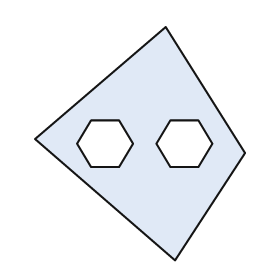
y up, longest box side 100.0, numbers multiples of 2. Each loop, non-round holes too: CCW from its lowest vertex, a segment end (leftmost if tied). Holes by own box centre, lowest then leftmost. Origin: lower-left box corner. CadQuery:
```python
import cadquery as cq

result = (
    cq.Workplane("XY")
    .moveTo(60.0, 0.0)
    .lineTo(90.0, 46.0)
    .lineTo(56.0, 100.0)
    .lineTo(0.0, 52.0)
    .close()
    .moveTo(24.0, 40.0)
    .lineTo(36.0, 40.0)
    .lineTo(42.0, 50.0)
    .lineTo(36.0, 60.0)
    .lineTo(24.0, 60.0)
    .lineTo(18.0, 50.0)
    .close()
    .moveTo(58.0, 40.0)
    .lineTo(70.0, 40.0)
    .lineTo(76.0, 50.0)
    .lineTo(70.0, 60.0)
    .lineTo(58.0, 60.0)
    .lineTo(52.0, 50.0)
    .close()
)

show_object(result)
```